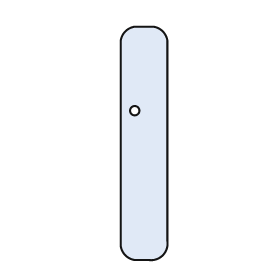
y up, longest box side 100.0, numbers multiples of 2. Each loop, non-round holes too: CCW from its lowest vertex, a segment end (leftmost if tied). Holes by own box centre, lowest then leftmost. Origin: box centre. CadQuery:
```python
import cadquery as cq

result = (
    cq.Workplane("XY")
    .moveTo(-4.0, -50.0)
    .lineTo(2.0, -50.0)
    .threePointArc((8.0, -48.0), (10.0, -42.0))
    .lineTo(10.0, 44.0)
    .threePointArc((8.0, 48.0), (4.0, 50.0))
    .lineTo(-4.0, 50.0)
    .threePointArc((-8.0, 48.0), (-10.0, 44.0))
    .lineTo(-10.0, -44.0)
    .threePointArc((-8.0, -48.0), (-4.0, -50.0))
    .close()
    .moveTo(-4.0, 14.0)
    .circle(2.0)
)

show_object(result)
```